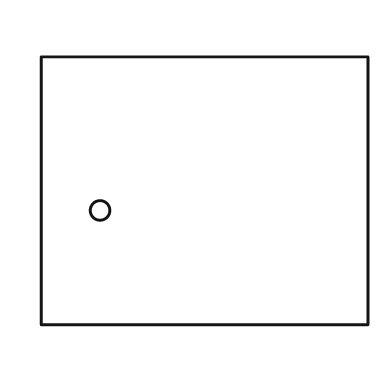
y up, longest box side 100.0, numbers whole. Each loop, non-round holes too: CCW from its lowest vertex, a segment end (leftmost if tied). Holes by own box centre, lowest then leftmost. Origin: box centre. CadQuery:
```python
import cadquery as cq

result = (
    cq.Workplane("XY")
    .moveTo(-50.0, -41.0)
    .lineTo(50.0, -41.0)
    .lineTo(50.0, 41.0)
    .lineTo(-50.0, 41.0)
    .close()
    .moveTo(-32.0, -6.0)
    .circle(3.0)
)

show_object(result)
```